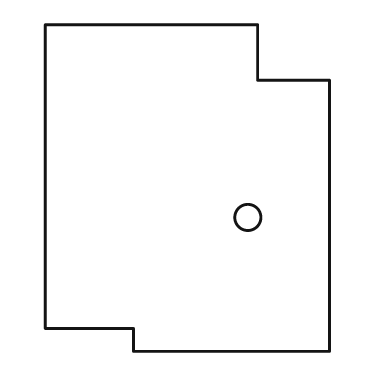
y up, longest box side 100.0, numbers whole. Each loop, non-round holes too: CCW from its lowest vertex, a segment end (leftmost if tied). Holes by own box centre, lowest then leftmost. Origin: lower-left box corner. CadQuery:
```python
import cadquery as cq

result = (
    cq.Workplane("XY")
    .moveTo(27.0, 0.0)
    .lineTo(87.0, 0.0)
    .lineTo(87.0, 83.0)
    .lineTo(65.0, 83.0)
    .lineTo(65.0, 100.0)
    .lineTo(0.0, 100.0)
    .lineTo(0.0, 7.0)
    .lineTo(27.0, 7.0)
    .close()
    .moveTo(62.0, 41.0)
    .circle(4.0)
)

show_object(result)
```